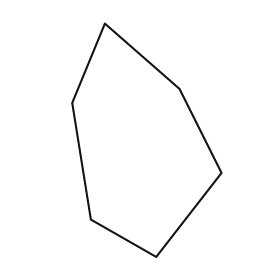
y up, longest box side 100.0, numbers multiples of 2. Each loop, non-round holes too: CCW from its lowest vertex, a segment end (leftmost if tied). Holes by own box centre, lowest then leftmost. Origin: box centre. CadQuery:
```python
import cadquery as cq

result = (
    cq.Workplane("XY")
    .moveTo(4.0, -50.0)
    .lineTo(32.0, -14.0)
    .lineTo(14.0, 22.0)
    .lineTo(-18.0, 50.0)
    .lineTo(-32.0, 16.0)
    .lineTo(-24.0, -34.0)
    .close()
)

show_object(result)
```